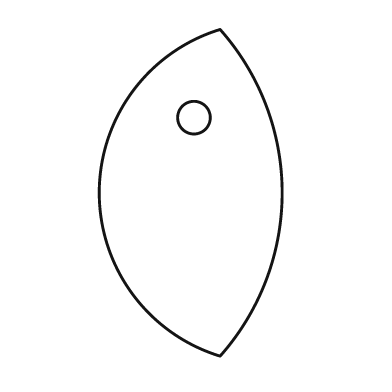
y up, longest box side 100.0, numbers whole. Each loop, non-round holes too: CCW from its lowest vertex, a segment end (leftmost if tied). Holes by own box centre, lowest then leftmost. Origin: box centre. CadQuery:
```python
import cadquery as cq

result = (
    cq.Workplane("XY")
    .moveTo(9.0, -50.0)
    .threePointArc((28.0, 0.0), (9.0, 50.0))
    .threePointArc((-28.0, 0.0), (9.0, -50.0))
    .close()
    .moveTo(1.0, 23.0)
    .circle(5.0)
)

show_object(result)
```